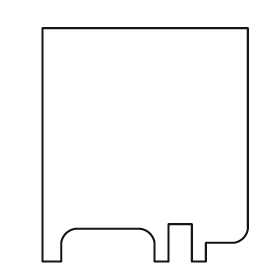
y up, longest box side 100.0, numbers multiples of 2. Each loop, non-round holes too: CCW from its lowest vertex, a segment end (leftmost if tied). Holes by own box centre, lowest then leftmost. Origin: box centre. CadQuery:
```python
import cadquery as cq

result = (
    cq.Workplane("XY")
    .moveTo(-44.0, -50.0)
    .lineTo(-36.0, -50.0)
    .lineTo(-36.0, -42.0)
    .threePointArc((-34.0, -38.0), (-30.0, -36.0))
    .lineTo(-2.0, -36.0)
    .threePointArc((2.0, -38.0), (4.0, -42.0))
    .lineTo(4.0, -50.0)
    .lineTo(10.0, -50.0)
    .lineTo(10.0, -34.0)
    .lineTo(20.0, -34.0)
    .lineTo(20.0, -50.0)
    .lineTo(26.0, -50.0)
    .lineTo(26.0, -42.0)
    .lineTo(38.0, -42.0)
    .threePointArc((42.0, -40.0), (44.0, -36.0))
    .lineTo(44.0, 50.0)
    .lineTo(-44.0, 50.0)
    .close()
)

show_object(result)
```